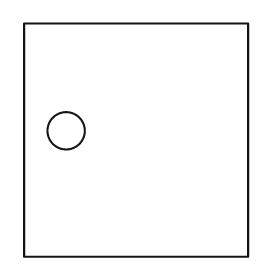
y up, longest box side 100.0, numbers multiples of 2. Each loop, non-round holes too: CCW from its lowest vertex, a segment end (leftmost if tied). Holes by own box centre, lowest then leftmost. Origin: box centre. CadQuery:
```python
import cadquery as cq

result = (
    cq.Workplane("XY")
    .moveTo(-48.0, -50.0)
    .lineTo(48.0, -50.0)
    .lineTo(48.0, 50.0)
    .lineTo(-48.0, 50.0)
    .close()
    .moveTo(-30.0, 4.0)
    .circle(8.0)
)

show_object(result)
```